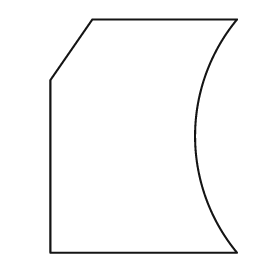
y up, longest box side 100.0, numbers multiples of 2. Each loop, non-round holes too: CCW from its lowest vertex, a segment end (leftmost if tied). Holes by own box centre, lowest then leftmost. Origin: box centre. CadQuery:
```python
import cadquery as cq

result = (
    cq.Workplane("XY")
    .moveTo(-40.0, -50.0)
    .lineTo(40.0, -50.0)
    .threePointArc((22.0, 0.0), (40.0, 50.0))
    .lineTo(-22.0, 50.0)
    .lineTo(-40.0, 24.0)
    .close()
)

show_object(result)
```